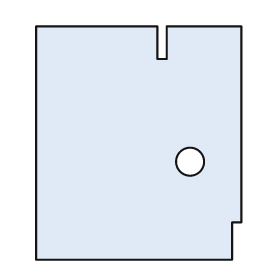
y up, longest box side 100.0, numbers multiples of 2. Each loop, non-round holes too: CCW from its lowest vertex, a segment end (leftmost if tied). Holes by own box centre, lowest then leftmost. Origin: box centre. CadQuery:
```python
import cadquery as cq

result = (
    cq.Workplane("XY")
    .moveTo(-44.0, -50.0)
    .lineTo(40.0, -50.0)
    .lineTo(40.0, -34.0)
    .lineTo(44.0, -34.0)
    .lineTo(44.0, 50.0)
    .lineTo(12.0, 50.0)
    .lineTo(12.0, 36.0)
    .lineTo(8.0, 36.0)
    .lineTo(8.0, 50.0)
    .lineTo(-44.0, 50.0)
    .close()
    .moveTo(22.0, -8.0)
    .circle(6.0)
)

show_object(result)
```